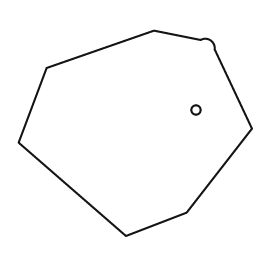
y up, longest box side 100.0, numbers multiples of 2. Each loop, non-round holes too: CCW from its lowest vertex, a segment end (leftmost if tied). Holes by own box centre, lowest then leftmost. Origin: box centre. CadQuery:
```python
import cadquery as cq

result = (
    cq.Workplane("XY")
    .moveTo(-4.0, -44.0)
    .lineTo(22.0, -34.0)
    .lineTo(50.0, 2.0)
    .lineTo(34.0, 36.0)
    .threePointArc((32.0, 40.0), (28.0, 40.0))
    .lineTo(8.0, 44.0)
    .lineTo(-38.0, 28.0)
    .lineTo(-50.0, -4.0)
    .close()
    .moveTo(26.0, 10.0)
    .circle(2.0)
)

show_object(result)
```